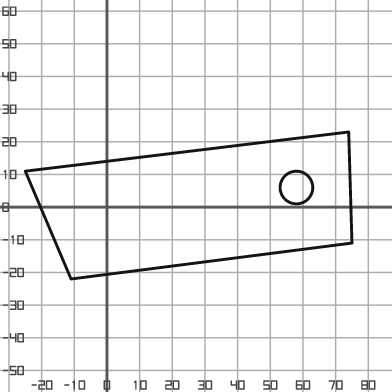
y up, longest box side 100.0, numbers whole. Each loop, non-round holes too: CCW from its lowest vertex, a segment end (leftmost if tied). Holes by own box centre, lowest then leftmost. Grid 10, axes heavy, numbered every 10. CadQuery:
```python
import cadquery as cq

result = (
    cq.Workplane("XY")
    .moveTo(-11.0, -22.0)
    .lineTo(75.0, -11.0)
    .lineTo(74.0, 23.0)
    .lineTo(-25.0, 11.0)
    .close()
    .moveTo(58.0, 6.0)
    .circle(5.0)
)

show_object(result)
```